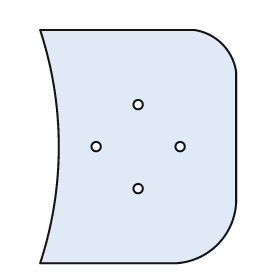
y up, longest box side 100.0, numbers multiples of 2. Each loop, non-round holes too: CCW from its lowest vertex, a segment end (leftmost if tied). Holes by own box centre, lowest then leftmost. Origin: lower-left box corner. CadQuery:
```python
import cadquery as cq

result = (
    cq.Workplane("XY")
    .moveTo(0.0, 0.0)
    .lineTo(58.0, 0.0)
    .threePointArc((76.0, 8.0), (84.0, 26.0))
    .lineTo(84.0, 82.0)
    .threePointArc((78.0, 94.0), (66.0, 100.0))
    .lineTo(0.0, 100.0)
    .threePointArc((8.0, 50.0), (0.0, 0.0))
    .close()
    .moveTo(42.0, 32.0)
    .circle(2.0)
    .moveTo(24.0, 50.0)
    .circle(2.0)
    .moveTo(60.0, 50.0)
    .circle(2.0)
    .moveTo(42.0, 68.0)
    .circle(2.0)
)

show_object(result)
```